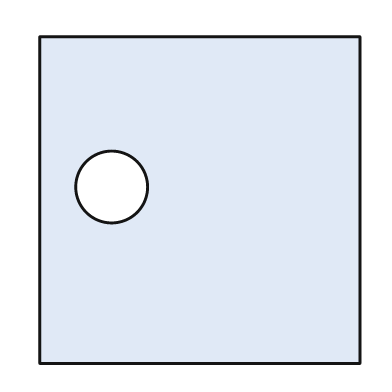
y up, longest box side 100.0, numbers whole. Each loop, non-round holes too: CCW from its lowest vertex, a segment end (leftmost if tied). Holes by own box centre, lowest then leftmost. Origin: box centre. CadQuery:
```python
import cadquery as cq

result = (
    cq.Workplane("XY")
    .moveTo(-49.0, -50.0)
    .lineTo(49.0, -50.0)
    .lineTo(49.0, 50.0)
    .lineTo(-49.0, 50.0)
    .close()
    .moveTo(-27.0, 4.0)
    .circle(11.0)
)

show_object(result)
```